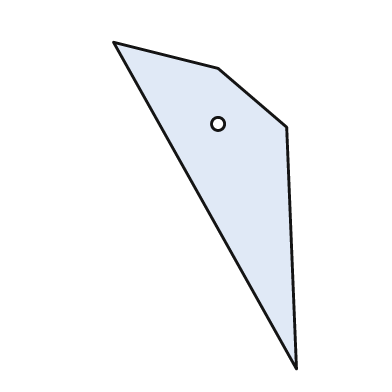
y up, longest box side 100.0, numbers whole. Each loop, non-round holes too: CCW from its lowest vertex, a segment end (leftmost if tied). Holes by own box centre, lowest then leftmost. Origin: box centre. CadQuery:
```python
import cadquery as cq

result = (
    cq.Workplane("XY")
    .moveTo(28.0, -50.0)
    .lineTo(25.0, 24.0)
    .lineTo(4.0, 42.0)
    .lineTo(-28.0, 50.0)
    .close()
    .moveTo(4.0, 25.0)
    .circle(2.0)
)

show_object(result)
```